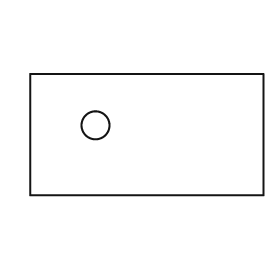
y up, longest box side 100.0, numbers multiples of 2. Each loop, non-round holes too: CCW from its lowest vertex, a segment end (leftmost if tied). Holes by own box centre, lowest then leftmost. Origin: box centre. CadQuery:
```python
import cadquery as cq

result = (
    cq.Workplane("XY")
    .moveTo(-50.0, -26.0)
    .lineTo(50.0, -26.0)
    .lineTo(50.0, 26.0)
    .lineTo(-50.0, 26.0)
    .close()
    .moveTo(-22.0, 4.0)
    .circle(6.0)
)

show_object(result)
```